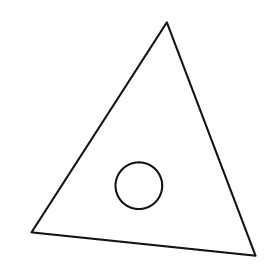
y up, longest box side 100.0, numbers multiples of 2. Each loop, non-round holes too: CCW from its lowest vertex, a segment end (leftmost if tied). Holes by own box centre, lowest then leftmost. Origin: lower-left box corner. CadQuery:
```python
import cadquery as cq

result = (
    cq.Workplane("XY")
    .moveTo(96.0, 0.0)
    .lineTo(58.0, 100.0)
    .lineTo(0.0, 10.0)
    .close()
    .moveTo(46.0, 30.0)
    .circle(10.0)
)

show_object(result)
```